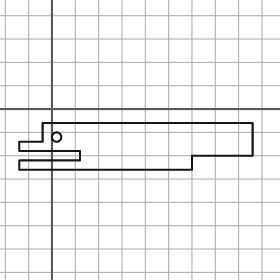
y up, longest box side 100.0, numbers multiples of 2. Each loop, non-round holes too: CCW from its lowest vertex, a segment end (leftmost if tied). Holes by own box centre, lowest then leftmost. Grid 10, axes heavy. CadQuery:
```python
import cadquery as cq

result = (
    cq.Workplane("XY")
    .moveTo(-14.0, -26.0)
    .lineTo(60.0, -26.0)
    .lineTo(60.0, -20.0)
    .lineTo(86.0, -20.0)
    .lineTo(86.0, -6.0)
    .lineTo(-4.0, -6.0)
    .lineTo(-4.0, -14.0)
    .lineTo(-14.0, -14.0)
    .lineTo(-14.0, -18.0)
    .lineTo(12.0, -18.0)
    .lineTo(12.0, -22.0)
    .lineTo(-14.0, -22.0)
    .close()
    .moveTo(2.0, -12.0)
    .circle(2.0)
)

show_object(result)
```